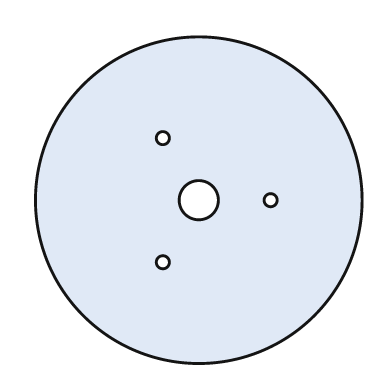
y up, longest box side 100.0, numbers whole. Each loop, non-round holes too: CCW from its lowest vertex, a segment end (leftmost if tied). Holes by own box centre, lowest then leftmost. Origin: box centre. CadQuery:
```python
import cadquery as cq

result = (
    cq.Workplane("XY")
    .moveTo(0.0, 0.0)
    .circle(50.0)
    .moveTo(-11.0, -19.0)
    .circle(2.0)
    .moveTo(0.0, 0.0)
    .circle(6.0)
    .moveTo(22.0, 0.0)
    .circle(2.0)
    .moveTo(-11.0, 19.0)
    .circle(2.0)
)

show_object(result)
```